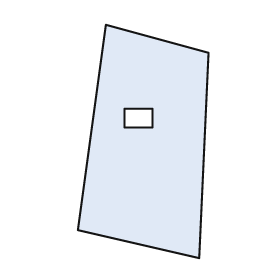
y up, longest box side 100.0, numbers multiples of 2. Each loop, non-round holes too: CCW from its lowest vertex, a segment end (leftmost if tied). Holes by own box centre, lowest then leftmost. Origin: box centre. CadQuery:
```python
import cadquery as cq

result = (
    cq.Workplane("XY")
    .moveTo(24.0, -50.0)
    .lineTo(28.0, 38.0)
    .lineTo(-16.0, 50.0)
    .lineTo(-28.0, -38.0)
    .close()
    .moveTo(-8.0, 6.0)
    .lineTo(4.0, 6.0)
    .lineTo(4.0, 14.0)
    .lineTo(-8.0, 14.0)
    .close()
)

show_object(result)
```